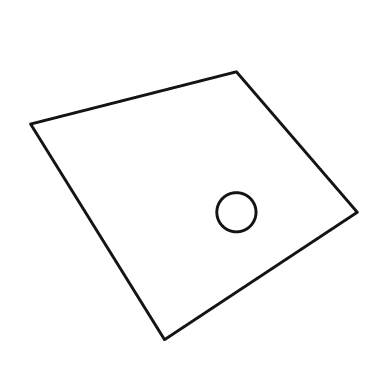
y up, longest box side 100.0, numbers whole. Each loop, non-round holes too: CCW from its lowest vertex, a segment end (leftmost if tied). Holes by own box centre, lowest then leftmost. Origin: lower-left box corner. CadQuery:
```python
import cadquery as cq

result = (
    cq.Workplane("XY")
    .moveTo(41.0, 0.0)
    .lineTo(100.0, 39.0)
    .lineTo(63.0, 82.0)
    .lineTo(0.0, 66.0)
    .close()
    .moveTo(63.0, 39.0)
    .circle(6.0)
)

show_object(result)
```